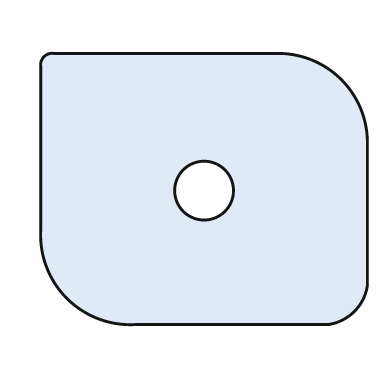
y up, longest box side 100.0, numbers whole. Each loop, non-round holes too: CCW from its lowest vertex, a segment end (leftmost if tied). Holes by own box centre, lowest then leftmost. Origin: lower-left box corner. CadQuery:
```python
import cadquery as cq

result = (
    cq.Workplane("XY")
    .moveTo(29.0, 0.0)
    .lineTo(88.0, 0.0)
    .threePointArc((96.0, 4.0), (100.0, 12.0))
    .lineTo(100.0, 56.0)
    .threePointArc((92.0, 75.0), (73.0, 83.0))
    .lineTo(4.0, 83.0)
    .threePointArc((1.0, 82.0), (0.0, 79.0))
    .lineTo(0.0, 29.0)
    .threePointArc((8.0, 8.0), (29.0, 0.0))
    .close()
    .moveTo(50.0, 41.0)
    .circle(9.0)
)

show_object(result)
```